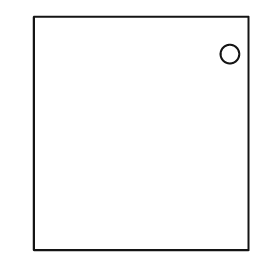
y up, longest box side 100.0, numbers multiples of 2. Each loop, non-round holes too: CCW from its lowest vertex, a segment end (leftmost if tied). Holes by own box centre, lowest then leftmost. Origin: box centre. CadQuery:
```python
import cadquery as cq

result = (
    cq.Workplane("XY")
    .moveTo(-46.0, -50.0)
    .lineTo(46.0, -50.0)
    .lineTo(46.0, 50.0)
    .lineTo(-46.0, 50.0)
    .close()
    .moveTo(38.0, 34.0)
    .circle(4.0)
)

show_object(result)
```